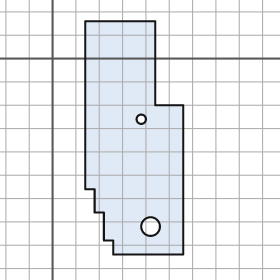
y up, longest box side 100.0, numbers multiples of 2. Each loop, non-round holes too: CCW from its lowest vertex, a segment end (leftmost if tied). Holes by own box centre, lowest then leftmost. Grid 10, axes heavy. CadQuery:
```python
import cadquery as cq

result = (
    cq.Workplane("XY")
    .moveTo(26.0, -84.0)
    .lineTo(56.0, -84.0)
    .lineTo(56.0, -20.0)
    .lineTo(44.0, -20.0)
    .lineTo(44.0, 16.0)
    .lineTo(14.0, 16.0)
    .lineTo(14.0, -56.0)
    .lineTo(18.0, -56.0)
    .lineTo(18.0, -66.0)
    .lineTo(22.0, -66.0)
    .lineTo(22.0, -78.0)
    .lineTo(26.0, -78.0)
    .close()
    .moveTo(42.0, -72.0)
    .circle(4.0)
    .moveTo(38.0, -26.0)
    .circle(2.0)
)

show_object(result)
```